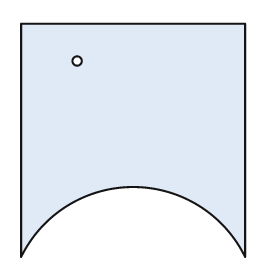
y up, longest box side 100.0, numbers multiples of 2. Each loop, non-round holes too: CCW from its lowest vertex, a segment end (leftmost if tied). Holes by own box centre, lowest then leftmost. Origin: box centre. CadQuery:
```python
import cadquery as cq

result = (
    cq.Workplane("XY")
    .moveTo(-48.0, -50.0)
    .threePointArc((0.0, -20.0), (48.0, -50.0))
    .lineTo(48.0, 50.0)
    .lineTo(-48.0, 50.0)
    .close()
    .moveTo(-24.0, 34.0)
    .circle(2.0)
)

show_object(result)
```